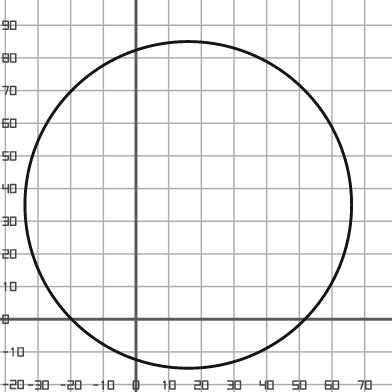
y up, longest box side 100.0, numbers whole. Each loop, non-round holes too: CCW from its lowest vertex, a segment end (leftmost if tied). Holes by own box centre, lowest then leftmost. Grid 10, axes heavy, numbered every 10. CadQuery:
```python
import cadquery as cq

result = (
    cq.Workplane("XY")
    .moveTo(16.0, 35.0)
    .circle(50.0)
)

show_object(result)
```